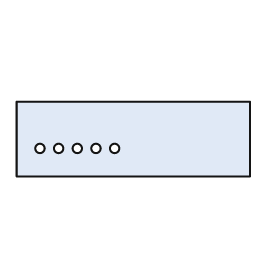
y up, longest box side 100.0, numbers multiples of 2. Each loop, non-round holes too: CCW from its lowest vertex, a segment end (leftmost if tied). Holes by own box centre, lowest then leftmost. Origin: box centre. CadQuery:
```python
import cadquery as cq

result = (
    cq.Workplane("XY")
    .moveTo(-50.0, -16.0)
    .lineTo(50.0, -16.0)
    .lineTo(50.0, 16.0)
    .lineTo(-50.0, 16.0)
    .close()
    .moveTo(-40.0, -4.0)
    .circle(2.0)
    .moveTo(-32.0, -4.0)
    .circle(2.0)
    .moveTo(-24.0, -4.0)
    .circle(2.0)
    .moveTo(-16.0, -4.0)
    .circle(2.0)
    .moveTo(-8.0, -4.0)
    .circle(2.0)
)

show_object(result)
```